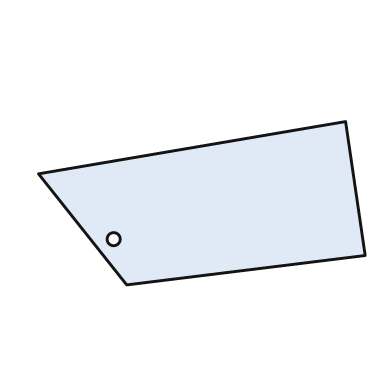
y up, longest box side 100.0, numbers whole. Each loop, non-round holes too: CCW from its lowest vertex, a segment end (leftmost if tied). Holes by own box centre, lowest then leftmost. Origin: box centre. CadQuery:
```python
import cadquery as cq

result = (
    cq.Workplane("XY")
    .moveTo(-23.0, -25.0)
    .lineTo(50.0, -16.0)
    .lineTo(44.0, 25.0)
    .lineTo(-50.0, 9.0)
    .close()
    .moveTo(-27.0, -11.0)
    .circle(2.0)
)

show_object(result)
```